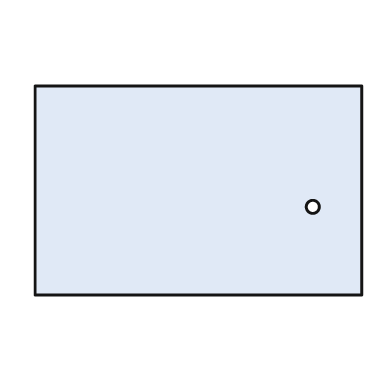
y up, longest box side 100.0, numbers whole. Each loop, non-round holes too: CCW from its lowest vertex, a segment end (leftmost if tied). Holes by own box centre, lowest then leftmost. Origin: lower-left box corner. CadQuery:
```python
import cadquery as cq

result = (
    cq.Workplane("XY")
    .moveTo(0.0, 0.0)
    .lineTo(100.0, 0.0)
    .lineTo(100.0, 64.0)
    .lineTo(0.0, 64.0)
    .close()
    .moveTo(85.0, 27.0)
    .circle(2.0)
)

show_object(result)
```